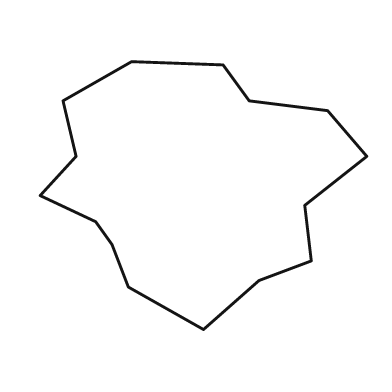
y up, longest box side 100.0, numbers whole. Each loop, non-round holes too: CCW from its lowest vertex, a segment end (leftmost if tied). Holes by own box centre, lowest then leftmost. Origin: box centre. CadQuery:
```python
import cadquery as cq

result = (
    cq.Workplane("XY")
    .moveTo(0.0, -41.0)
    .lineTo(17.0, -26.0)
    .lineTo(33.0, -20.0)
    .lineTo(31.0, -3.0)
    .lineTo(50.0, 12.0)
    .lineTo(38.0, 26.0)
    .lineTo(14.0, 29.0)
    .lineTo(6.0, 40.0)
    .lineTo(-22.0, 41.0)
    .lineTo(-43.0, 29.0)
    .lineTo(-39.0, 12.0)
    .lineTo(-50.0, 0.0)
    .lineTo(-33.0, -8.0)
    .lineTo(-28.0, -15.0)
    .lineTo(-23.0, -28.0)
    .close()
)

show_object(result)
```